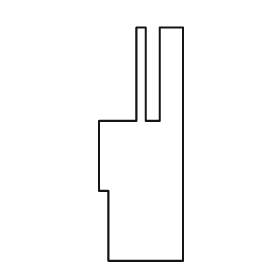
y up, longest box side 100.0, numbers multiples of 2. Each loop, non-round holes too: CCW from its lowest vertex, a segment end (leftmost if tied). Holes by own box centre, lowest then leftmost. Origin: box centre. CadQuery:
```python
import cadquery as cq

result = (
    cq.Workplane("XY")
    .moveTo(-14.0, -50.0)
    .lineTo(18.0, -50.0)
    .lineTo(18.0, 50.0)
    .lineTo(8.0, 50.0)
    .lineTo(8.0, 10.0)
    .lineTo(2.0, 10.0)
    .lineTo(2.0, 50.0)
    .lineTo(-2.0, 50.0)
    .lineTo(-2.0, 10.0)
    .lineTo(-18.0, 10.0)
    .lineTo(-18.0, -20.0)
    .lineTo(-14.0, -20.0)
    .close()
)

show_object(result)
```